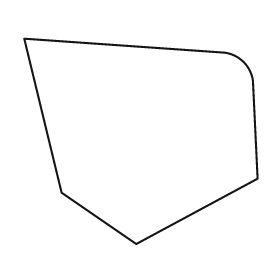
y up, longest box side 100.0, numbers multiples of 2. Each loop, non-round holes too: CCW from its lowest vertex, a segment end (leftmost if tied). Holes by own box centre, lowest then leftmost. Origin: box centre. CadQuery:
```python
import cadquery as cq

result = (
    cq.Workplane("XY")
    .moveTo(-2.0, -44.0)
    .lineTo(50.0, -16.0)
    .lineTo(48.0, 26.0)
    .threePointArc((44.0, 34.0), (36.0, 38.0))
    .lineTo(-50.0, 44.0)
    .lineTo(-34.0, -22.0)
    .close()
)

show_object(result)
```